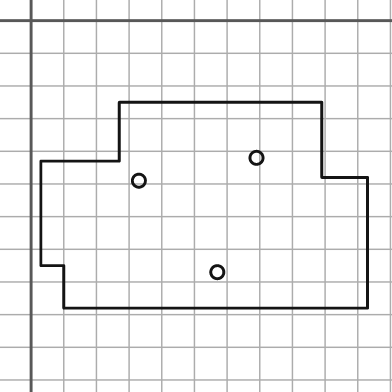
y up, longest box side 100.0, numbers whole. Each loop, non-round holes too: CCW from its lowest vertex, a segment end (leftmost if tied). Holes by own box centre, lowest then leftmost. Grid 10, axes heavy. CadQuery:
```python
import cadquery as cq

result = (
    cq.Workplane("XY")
    .moveTo(10.0, -88.0)
    .lineTo(103.0, -88.0)
    .lineTo(103.0, -48.0)
    .lineTo(89.0, -48.0)
    .lineTo(89.0, -25.0)
    .lineTo(27.0, -25.0)
    .lineTo(27.0, -43.0)
    .lineTo(3.0, -43.0)
    .lineTo(3.0, -75.0)
    .lineTo(10.0, -75.0)
    .close()
    .moveTo(57.0, -77.0)
    .circle(2.0)
    .moveTo(33.0, -49.0)
    .circle(2.0)
    .moveTo(69.0, -42.0)
    .circle(2.0)
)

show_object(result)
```